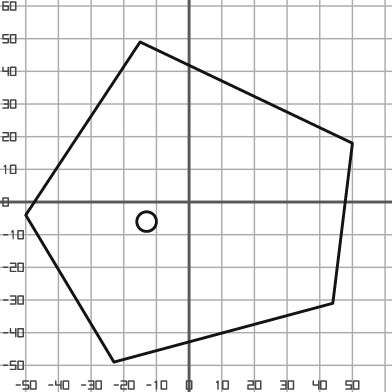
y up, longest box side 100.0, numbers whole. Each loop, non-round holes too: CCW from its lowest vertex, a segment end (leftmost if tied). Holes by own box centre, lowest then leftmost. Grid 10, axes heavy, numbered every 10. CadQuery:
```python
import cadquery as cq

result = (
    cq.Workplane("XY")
    .moveTo(-23.0, -49.0)
    .lineTo(44.0, -31.0)
    .lineTo(50.0, 18.0)
    .lineTo(-15.0, 49.0)
    .lineTo(-50.0, -4.0)
    .close()
    .moveTo(-13.0, -6.0)
    .circle(3.0)
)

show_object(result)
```